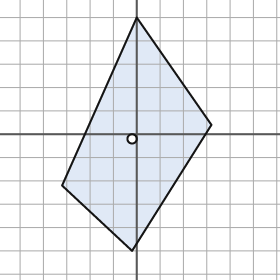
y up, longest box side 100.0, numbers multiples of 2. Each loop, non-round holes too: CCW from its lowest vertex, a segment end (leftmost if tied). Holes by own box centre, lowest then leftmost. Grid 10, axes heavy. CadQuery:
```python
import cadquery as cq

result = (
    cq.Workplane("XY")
    .moveTo(-2.0, -50.0)
    .lineTo(32.0, 4.0)
    .lineTo(0.0, 50.0)
    .lineTo(-32.0, -22.0)
    .close()
    .moveTo(-2.0, -2.0)
    .circle(2.0)
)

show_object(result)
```